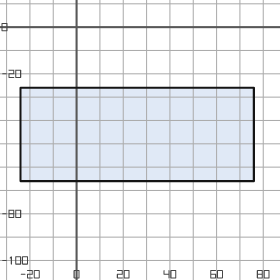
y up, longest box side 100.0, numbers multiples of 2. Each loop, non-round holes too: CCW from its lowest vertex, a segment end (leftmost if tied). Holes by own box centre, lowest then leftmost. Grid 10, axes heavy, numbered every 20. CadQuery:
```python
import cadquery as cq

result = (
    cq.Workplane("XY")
    .moveTo(-24.0, -66.0)
    .lineTo(76.0, -66.0)
    .lineTo(76.0, -26.0)
    .lineTo(-24.0, -26.0)
    .close()
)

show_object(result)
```